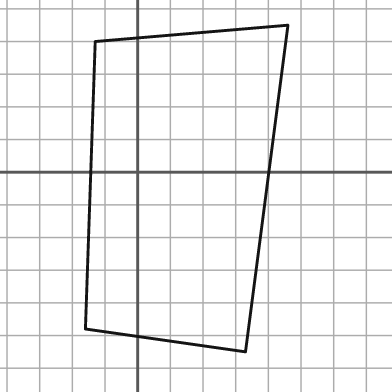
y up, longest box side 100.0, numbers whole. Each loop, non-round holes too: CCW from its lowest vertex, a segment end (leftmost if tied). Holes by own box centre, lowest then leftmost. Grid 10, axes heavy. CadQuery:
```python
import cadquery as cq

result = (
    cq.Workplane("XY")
    .moveTo(33.0, -55.0)
    .lineTo(46.0, 45.0)
    .lineTo(-13.0, 40.0)
    .lineTo(-16.0, -48.0)
    .close()
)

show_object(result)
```